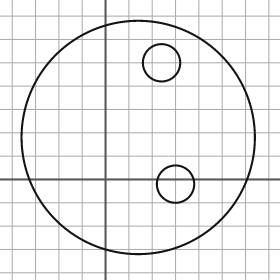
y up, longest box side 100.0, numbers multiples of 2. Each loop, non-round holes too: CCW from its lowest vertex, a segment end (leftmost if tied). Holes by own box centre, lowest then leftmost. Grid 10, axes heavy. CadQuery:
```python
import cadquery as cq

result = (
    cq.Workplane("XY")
    .moveTo(14.0, 18.0)
    .circle(50.0)
    .moveTo(30.0, -2.0)
    .circle(8.0)
    .moveTo(24.0, 50.0)
    .circle(8.0)
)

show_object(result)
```